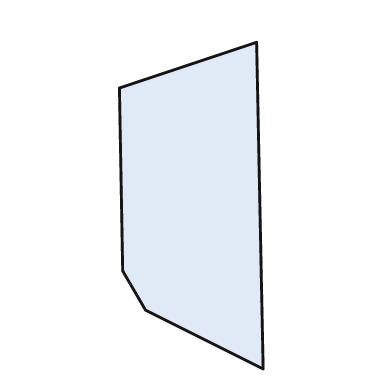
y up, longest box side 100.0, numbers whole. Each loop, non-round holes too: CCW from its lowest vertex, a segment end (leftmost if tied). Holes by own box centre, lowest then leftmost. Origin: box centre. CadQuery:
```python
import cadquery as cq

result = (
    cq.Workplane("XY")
    .moveTo(22.0, -50.0)
    .lineTo(20.0, 50.0)
    .lineTo(-22.0, 36.0)
    .lineTo(-21.0, -20.0)
    .lineTo(-14.0, -32.0)
    .close()
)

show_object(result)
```